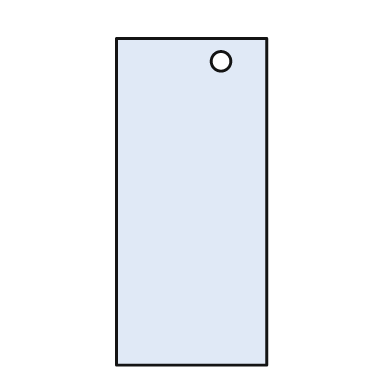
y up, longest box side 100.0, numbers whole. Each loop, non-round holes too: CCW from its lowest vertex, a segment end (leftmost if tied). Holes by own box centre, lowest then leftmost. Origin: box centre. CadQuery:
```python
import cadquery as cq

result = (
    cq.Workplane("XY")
    .moveTo(-23.0, -50.0)
    .lineTo(23.0, -50.0)
    .lineTo(23.0, 50.0)
    .lineTo(-23.0, 50.0)
    .close()
    .moveTo(9.0, 43.0)
    .circle(3.0)
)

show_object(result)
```